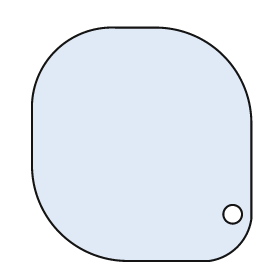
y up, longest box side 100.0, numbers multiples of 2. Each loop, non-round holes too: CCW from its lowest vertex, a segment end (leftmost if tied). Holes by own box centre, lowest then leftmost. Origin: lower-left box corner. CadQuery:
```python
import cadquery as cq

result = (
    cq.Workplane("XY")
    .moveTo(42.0, 0.0)
    .lineTo(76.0, 0.0)
    .threePointArc((88.0, 6.0), (94.0, 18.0))
    .lineTo(94.0, 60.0)
    .threePointArc((82.0, 88.0), (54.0, 100.0))
    .lineTo(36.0, 100.0)
    .threePointArc((10.0, 90.0), (0.0, 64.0))
    .lineTo(0.0, 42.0)
    .threePointArc((12.0, 12.0), (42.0, 0.0))
    .close()
    .moveTo(86.0, 20.0)
    .circle(4.0)
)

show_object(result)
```